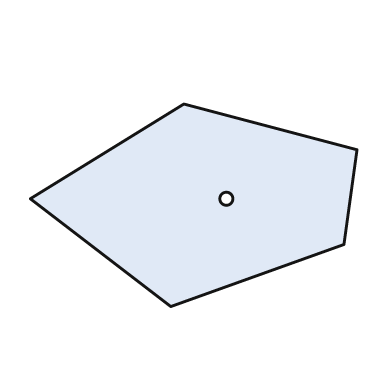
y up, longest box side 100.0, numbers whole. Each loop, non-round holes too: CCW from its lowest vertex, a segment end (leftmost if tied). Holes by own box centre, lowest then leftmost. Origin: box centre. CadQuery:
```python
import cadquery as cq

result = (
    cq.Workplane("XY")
    .moveTo(-7.0, -31.0)
    .lineTo(46.0, -12.0)
    .lineTo(50.0, 17.0)
    .lineTo(-3.0, 31.0)
    .lineTo(-50.0, 2.0)
    .close()
    .moveTo(10.0, 2.0)
    .circle(2.0)
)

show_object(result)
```